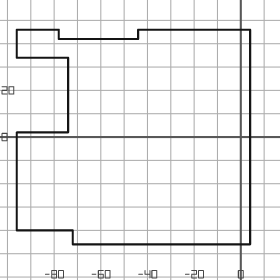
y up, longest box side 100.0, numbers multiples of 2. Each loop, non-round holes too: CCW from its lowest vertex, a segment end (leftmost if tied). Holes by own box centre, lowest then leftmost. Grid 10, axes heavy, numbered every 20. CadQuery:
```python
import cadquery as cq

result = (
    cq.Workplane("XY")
    .moveTo(-72.0, -46.0)
    .lineTo(4.0, -46.0)
    .lineTo(4.0, 46.0)
    .lineTo(-44.0, 46.0)
    .lineTo(-44.0, 42.0)
    .lineTo(-78.0, 42.0)
    .lineTo(-78.0, 46.0)
    .lineTo(-96.0, 46.0)
    .lineTo(-96.0, 34.0)
    .lineTo(-74.0, 34.0)
    .lineTo(-74.0, 2.0)
    .lineTo(-96.0, 2.0)
    .lineTo(-96.0, -40.0)
    .lineTo(-72.0, -40.0)
    .close()
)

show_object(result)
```